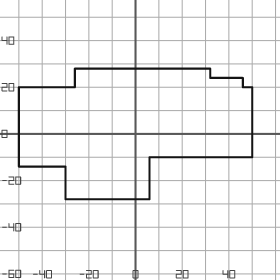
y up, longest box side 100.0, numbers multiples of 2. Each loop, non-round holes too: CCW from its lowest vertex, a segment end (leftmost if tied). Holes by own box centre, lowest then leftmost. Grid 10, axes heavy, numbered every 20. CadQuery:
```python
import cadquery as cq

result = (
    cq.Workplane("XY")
    .moveTo(-30.0, -28.0)
    .lineTo(6.0, -28.0)
    .lineTo(6.0, -10.0)
    .lineTo(50.0, -10.0)
    .lineTo(50.0, 20.0)
    .lineTo(46.0, 20.0)
    .lineTo(46.0, 24.0)
    .lineTo(32.0, 24.0)
    .lineTo(32.0, 28.0)
    .lineTo(-26.0, 28.0)
    .lineTo(-26.0, 20.0)
    .lineTo(-50.0, 20.0)
    .lineTo(-50.0, -14.0)
    .lineTo(-30.0, -14.0)
    .close()
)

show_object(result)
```